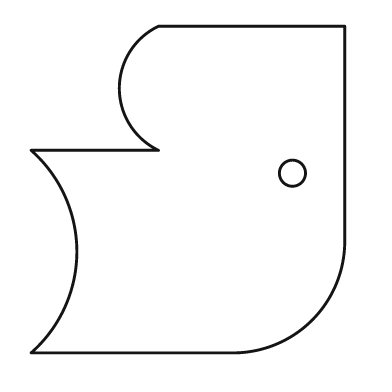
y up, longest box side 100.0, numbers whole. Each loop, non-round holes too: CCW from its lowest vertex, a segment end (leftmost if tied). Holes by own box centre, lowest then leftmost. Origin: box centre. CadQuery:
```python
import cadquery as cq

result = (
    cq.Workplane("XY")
    .moveTo(-48.0, -50.0)
    .lineTo(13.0, -50.0)
    .threePointArc((38.0, -40.0), (48.0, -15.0))
    .lineTo(48.0, 50.0)
    .lineTo(-9.0, 50.0)
    .threePointArc((-21.0, 31.0), (-9.0, 12.0))
    .lineTo(-48.0, 12.0)
    .threePointArc((-34.0, -19.0), (-48.0, -50.0))
    .close()
    .moveTo(32.0, 5.0)
    .circle(4.0)
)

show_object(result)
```